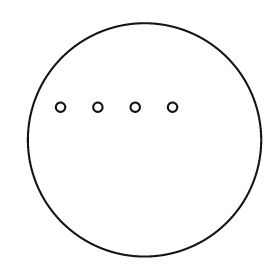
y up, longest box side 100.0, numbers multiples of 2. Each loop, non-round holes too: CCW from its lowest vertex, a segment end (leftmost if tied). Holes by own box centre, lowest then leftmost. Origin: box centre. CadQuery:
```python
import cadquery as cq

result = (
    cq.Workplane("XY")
    .moveTo(0.0, 0.0)
    .circle(50.0)
    .moveTo(-36.0, 14.0)
    .circle(2.0)
    .moveTo(-20.0, 14.0)
    .circle(2.0)
    .moveTo(-4.0, 14.0)
    .circle(2.0)
    .moveTo(12.0, 14.0)
    .circle(2.0)
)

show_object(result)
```